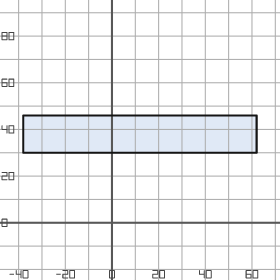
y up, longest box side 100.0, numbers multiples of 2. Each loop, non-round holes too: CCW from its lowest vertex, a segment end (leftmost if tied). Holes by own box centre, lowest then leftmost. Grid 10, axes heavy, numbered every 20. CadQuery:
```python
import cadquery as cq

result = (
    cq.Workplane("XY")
    .moveTo(-38.0, 30.0)
    .lineTo(62.0, 30.0)
    .lineTo(62.0, 46.0)
    .lineTo(-38.0, 46.0)
    .close()
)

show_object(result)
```